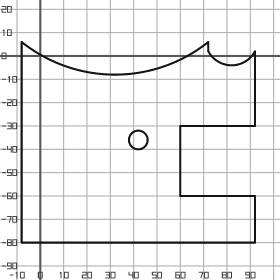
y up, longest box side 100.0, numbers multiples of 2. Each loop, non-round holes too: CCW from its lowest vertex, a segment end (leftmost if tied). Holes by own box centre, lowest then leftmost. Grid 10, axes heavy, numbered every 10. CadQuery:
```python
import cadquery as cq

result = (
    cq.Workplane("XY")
    .moveTo(-8.0, -80.0)
    .lineTo(92.0, -80.0)
    .lineTo(92.0, -60.0)
    .lineTo(60.0, -60.0)
    .lineTo(60.0, -30.0)
    .lineTo(92.0, -30.0)
    .lineTo(92.0, 2.0)
    .threePointArc((82.0, -4.0), (72.0, 2.0))
    .lineTo(72.0, 6.0)
    .threePointArc((32.0, -8.0), (-8.0, 6.0))
    .close()
    .moveTo(42.0, -36.0)
    .circle(4.0)
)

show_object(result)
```